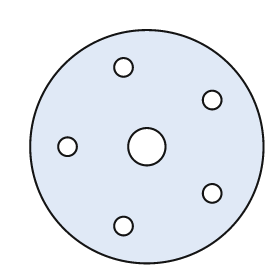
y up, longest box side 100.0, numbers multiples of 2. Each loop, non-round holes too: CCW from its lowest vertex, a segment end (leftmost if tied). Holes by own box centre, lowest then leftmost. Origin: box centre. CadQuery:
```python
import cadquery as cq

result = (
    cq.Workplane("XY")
    .moveTo(0.0, 0.0)
    .circle(50.0)
    .moveTo(-10.0, -34.0)
    .circle(4.0)
    .moveTo(28.0, -20.0)
    .circle(4.0)
    .moveTo(-34.0, 0.0)
    .circle(4.0)
    .moveTo(0.0, 0.0)
    .circle(8.0)
    .moveTo(28.0, 20.0)
    .circle(4.0)
    .moveTo(-10.0, 34.0)
    .circle(4.0)
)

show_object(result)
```